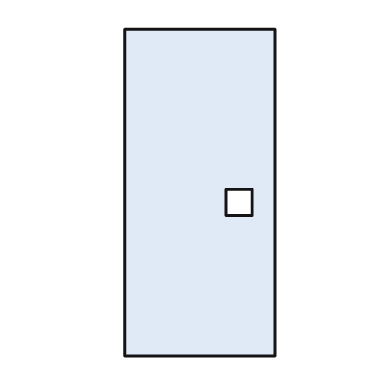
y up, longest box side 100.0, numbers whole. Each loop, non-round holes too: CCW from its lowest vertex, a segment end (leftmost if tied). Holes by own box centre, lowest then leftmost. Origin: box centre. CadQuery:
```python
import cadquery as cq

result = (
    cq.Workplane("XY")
    .moveTo(-23.0, -50.0)
    .lineTo(23.0, -50.0)
    .lineTo(23.0, 50.0)
    .lineTo(-23.0, 50.0)
    .close()
    .moveTo(8.0, -7.0)
    .lineTo(16.0, -7.0)
    .lineTo(16.0, 1.0)
    .lineTo(8.0, 1.0)
    .close()
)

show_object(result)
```